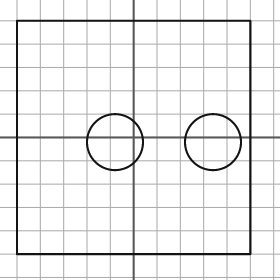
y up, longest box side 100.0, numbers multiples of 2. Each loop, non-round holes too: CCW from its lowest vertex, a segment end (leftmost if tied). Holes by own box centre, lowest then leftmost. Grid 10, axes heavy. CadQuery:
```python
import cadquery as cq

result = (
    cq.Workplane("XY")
    .moveTo(-50.0, -50.0)
    .lineTo(50.0, -50.0)
    .lineTo(50.0, 50.0)
    .lineTo(-50.0, 50.0)
    .close()
    .moveTo(-8.0, -2.0)
    .circle(12.0)
    .moveTo(34.0, -2.0)
    .circle(12.0)
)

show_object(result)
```